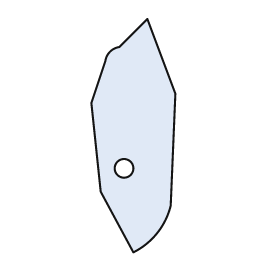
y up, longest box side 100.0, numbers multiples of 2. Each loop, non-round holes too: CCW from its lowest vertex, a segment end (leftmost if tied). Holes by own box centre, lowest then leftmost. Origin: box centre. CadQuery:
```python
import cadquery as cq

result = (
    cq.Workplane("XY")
    .moveTo(0.0, -50.0)
    .threePointArc((10.0, -42.0), (16.0, -30.0))
    .lineTo(18.0, 18.0)
    .lineTo(6.0, 50.0)
    .lineTo(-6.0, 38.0)
    .threePointArc((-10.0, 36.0), (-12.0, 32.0))
    .lineTo(-18.0, 14.0)
    .lineTo(-14.0, -24.0)
    .close()
    .moveTo(-4.0, -14.0)
    .circle(4.0)
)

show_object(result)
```